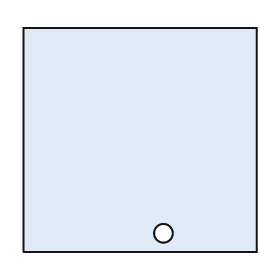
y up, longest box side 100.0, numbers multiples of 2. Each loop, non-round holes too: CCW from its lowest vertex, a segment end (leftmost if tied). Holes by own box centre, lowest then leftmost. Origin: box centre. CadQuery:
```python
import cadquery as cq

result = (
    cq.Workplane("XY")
    .moveTo(-50.0, -48.0)
    .lineTo(50.0, -48.0)
    .lineTo(50.0, 48.0)
    .lineTo(-50.0, 48.0)
    .close()
    .moveTo(10.0, -40.0)
    .circle(4.0)
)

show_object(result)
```